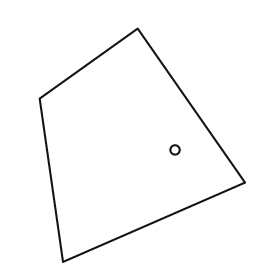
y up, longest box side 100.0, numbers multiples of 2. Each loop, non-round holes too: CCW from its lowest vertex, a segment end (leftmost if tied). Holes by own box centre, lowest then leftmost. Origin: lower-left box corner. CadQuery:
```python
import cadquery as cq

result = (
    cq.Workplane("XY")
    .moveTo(10.0, 0.0)
    .lineTo(88.0, 34.0)
    .lineTo(42.0, 100.0)
    .lineTo(0.0, 70.0)
    .close()
    .moveTo(58.0, 48.0)
    .circle(2.0)
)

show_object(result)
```